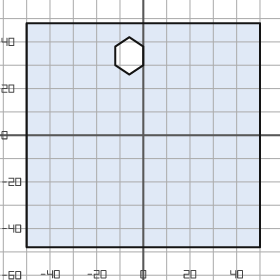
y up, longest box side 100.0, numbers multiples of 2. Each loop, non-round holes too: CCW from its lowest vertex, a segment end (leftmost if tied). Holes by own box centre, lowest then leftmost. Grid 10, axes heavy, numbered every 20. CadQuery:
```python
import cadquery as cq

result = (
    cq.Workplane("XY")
    .moveTo(-50.0, -48.0)
    .lineTo(50.0, -48.0)
    .lineTo(50.0, 48.0)
    .lineTo(-50.0, 48.0)
    .close()
    .moveTo(-6.0, 26.0)
    .lineTo(0.0, 30.0)
    .lineTo(0.0, 38.0)
    .lineTo(-6.0, 42.0)
    .lineTo(-12.0, 38.0)
    .lineTo(-12.0, 30.0)
    .close()
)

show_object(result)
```